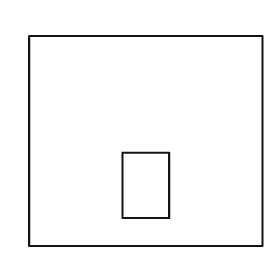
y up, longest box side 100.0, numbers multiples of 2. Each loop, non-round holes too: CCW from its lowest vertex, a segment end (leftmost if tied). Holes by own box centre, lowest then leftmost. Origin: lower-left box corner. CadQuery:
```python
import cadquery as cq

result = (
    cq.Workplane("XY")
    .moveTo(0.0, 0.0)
    .lineTo(100.0, 0.0)
    .lineTo(100.0, 90.0)
    .lineTo(0.0, 90.0)
    .close()
    .moveTo(40.0, 12.0)
    .lineTo(60.0, 12.0)
    .lineTo(60.0, 40.0)
    .lineTo(40.0, 40.0)
    .close()
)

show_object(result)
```